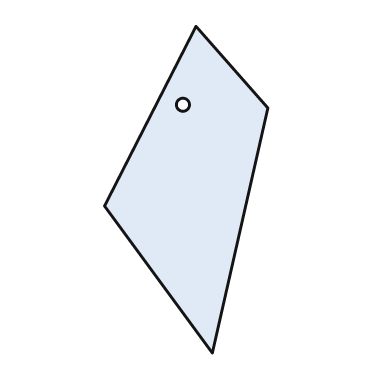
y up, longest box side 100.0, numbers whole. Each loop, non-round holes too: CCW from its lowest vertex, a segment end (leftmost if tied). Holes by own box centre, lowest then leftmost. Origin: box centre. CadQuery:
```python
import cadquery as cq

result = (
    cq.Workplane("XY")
    .moveTo(8.0, -50.0)
    .lineTo(25.0, 25.0)
    .lineTo(3.0, 50.0)
    .lineTo(-25.0, -5.0)
    .close()
    .moveTo(-1.0, 26.0)
    .circle(2.0)
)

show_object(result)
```